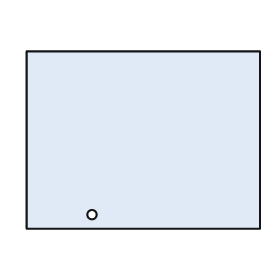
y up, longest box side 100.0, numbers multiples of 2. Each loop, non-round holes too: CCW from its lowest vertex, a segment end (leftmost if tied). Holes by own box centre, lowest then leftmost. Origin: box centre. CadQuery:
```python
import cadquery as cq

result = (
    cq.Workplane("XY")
    .moveTo(-50.0, -38.0)
    .lineTo(50.0, -38.0)
    .lineTo(50.0, 38.0)
    .lineTo(-50.0, 38.0)
    .close()
    .moveTo(-22.0, -32.0)
    .circle(2.0)
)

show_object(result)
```